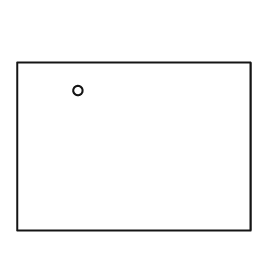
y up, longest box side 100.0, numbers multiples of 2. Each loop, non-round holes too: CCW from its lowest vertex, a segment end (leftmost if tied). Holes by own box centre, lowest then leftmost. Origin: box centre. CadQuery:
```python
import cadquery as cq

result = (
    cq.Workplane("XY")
    .moveTo(-50.0, -36.0)
    .lineTo(50.0, -36.0)
    .lineTo(50.0, 36.0)
    .lineTo(-50.0, 36.0)
    .close()
    .moveTo(-24.0, 24.0)
    .circle(2.0)
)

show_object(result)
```